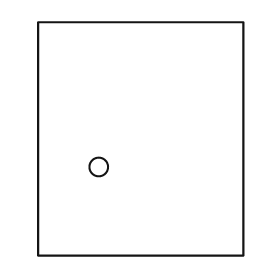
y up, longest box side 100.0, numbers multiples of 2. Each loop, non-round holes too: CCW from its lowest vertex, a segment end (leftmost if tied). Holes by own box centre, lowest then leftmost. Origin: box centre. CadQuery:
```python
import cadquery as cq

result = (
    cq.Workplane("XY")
    .moveTo(-44.0, -50.0)
    .lineTo(44.0, -50.0)
    .lineTo(44.0, 50.0)
    .lineTo(-44.0, 50.0)
    .close()
    .moveTo(-18.0, -12.0)
    .circle(4.0)
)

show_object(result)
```